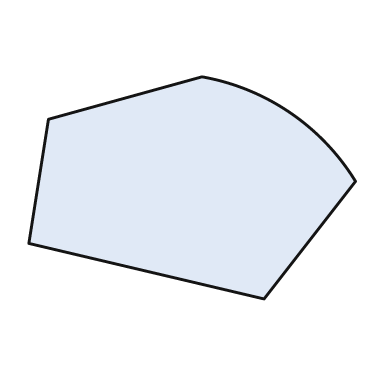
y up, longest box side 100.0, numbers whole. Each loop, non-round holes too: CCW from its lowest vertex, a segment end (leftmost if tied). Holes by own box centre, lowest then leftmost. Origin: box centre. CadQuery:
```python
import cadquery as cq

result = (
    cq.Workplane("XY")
    .moveTo(22.0, -34.0)
    .lineTo(50.0, 2.0)
    .threePointArc((30.0, 23.0), (3.0, 34.0))
    .lineTo(-44.0, 21.0)
    .lineTo(-50.0, -17.0)
    .close()
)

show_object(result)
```